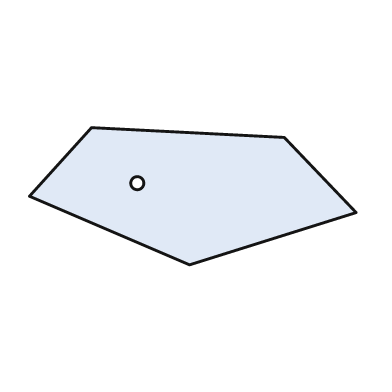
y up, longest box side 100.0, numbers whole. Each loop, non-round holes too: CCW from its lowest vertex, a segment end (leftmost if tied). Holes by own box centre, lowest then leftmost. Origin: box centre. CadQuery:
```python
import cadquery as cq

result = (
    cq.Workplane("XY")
    .moveTo(-1.0, -21.0)
    .lineTo(50.0, -5.0)
    .lineTo(28.0, 18.0)
    .lineTo(-31.0, 21.0)
    .lineTo(-50.0, 0.0)
    .close()
    .moveTo(-17.0, 4.0)
    .circle(2.0)
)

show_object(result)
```